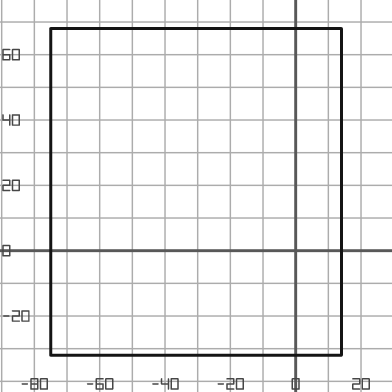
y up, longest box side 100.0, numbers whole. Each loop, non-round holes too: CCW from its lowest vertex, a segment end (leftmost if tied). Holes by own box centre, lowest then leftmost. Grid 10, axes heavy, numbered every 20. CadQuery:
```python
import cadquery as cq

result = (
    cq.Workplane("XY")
    .moveTo(-75.0, -32.0)
    .lineTo(14.0, -32.0)
    .lineTo(14.0, 68.0)
    .lineTo(-75.0, 68.0)
    .close()
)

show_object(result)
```